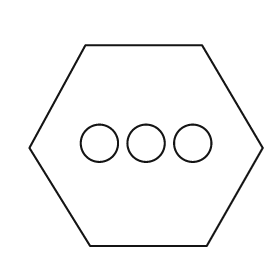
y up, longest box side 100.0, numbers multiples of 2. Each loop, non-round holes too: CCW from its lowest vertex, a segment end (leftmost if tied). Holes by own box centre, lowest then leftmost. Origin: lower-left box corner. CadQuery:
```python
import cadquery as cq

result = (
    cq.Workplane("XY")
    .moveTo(26.0, 0.0)
    .lineTo(76.0, 0.0)
    .lineTo(100.0, 42.0)
    .lineTo(74.0, 86.0)
    .lineTo(24.0, 86.0)
    .lineTo(0.0, 42.0)
    .close()
    .moveTo(30.0, 44.0)
    .circle(8.0)
    .moveTo(50.0, 44.0)
    .circle(8.0)
    .moveTo(70.0, 44.0)
    .circle(8.0)
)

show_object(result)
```